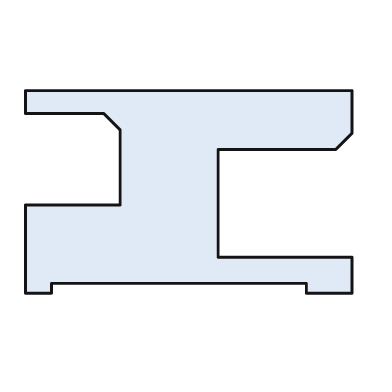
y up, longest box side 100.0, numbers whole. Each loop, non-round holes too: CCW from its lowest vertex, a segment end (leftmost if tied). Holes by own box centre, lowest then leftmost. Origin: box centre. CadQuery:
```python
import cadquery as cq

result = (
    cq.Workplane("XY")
    .moveTo(-50.0, -31.0)
    .lineTo(-42.0, -31.0)
    .lineTo(-42.0, -28.0)
    .lineTo(36.0, -28.0)
    .lineTo(36.0, -31.0)
    .lineTo(50.0, -31.0)
    .lineTo(50.0, -20.0)
    .lineTo(9.0, -20.0)
    .lineTo(9.0, 13.0)
    .lineTo(45.0, 13.0)
    .lineTo(50.0, 18.0)
    .lineTo(50.0, 31.0)
    .lineTo(-50.0, 31.0)
    .lineTo(-50.0, 24.0)
    .lineTo(-26.0, 24.0)
    .lineTo(-21.0, 19.0)
    .lineTo(-21.0, -4.0)
    .lineTo(-50.0, -4.0)
    .close()
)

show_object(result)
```